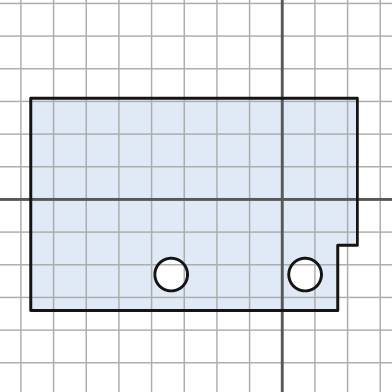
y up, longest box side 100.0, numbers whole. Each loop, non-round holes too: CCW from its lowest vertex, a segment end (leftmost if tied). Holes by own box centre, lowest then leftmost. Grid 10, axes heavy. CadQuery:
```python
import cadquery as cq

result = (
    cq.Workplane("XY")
    .moveTo(-77.0, -34.0)
    .lineTo(17.0, -34.0)
    .lineTo(17.0, -14.0)
    .lineTo(23.0, -14.0)
    .lineTo(23.0, 31.0)
    .lineTo(-77.0, 31.0)
    .close()
    .moveTo(-34.0, -23.0)
    .circle(5.0)
    .moveTo(7.0, -23.0)
    .circle(5.0)
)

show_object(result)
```